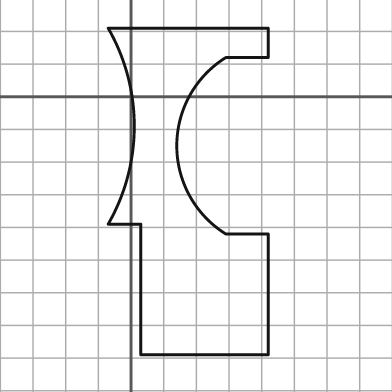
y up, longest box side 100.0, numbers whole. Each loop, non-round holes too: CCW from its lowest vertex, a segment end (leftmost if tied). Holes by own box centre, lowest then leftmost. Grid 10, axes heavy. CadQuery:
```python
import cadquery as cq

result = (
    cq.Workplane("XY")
    .moveTo(3.0, -79.0)
    .lineTo(42.0, -79.0)
    .lineTo(42.0, -42.0)
    .lineTo(29.0, -42.0)
    .threePointArc((14.0, -15.0), (29.0, 12.0))
    .lineTo(42.0, 12.0)
    .lineTo(42.0, 21.0)
    .lineTo(-7.0, 21.0)
    .threePointArc((1.0, -9.0), (-7.0, -39.0))
    .lineTo(3.0, -39.0)
    .close()
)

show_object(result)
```